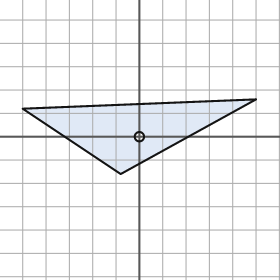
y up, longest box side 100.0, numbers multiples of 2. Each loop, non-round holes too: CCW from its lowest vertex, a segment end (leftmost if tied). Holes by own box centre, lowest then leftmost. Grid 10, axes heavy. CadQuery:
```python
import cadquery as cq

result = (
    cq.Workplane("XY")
    .moveTo(-8.0, -16.0)
    .lineTo(50.0, 16.0)
    .lineTo(-50.0, 12.0)
    .close()
    .moveTo(0.0, 0.0)
    .circle(2.0)
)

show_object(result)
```